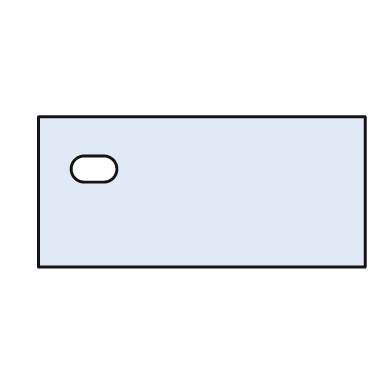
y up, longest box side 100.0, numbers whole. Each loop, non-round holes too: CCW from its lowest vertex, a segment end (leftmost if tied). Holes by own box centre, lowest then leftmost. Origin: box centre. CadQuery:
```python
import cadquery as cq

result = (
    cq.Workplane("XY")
    .moveTo(-50.0, -23.0)
    .lineTo(50.0, -23.0)
    .lineTo(50.0, 23.0)
    .lineTo(-50.0, 23.0)
    .close()
    .moveTo(-36.0, 3.0)
    .lineTo(-30.0, 3.0)
    .threePointArc((-26.0, 7.0), (-30.0, 11.0))
    .lineTo(-36.0, 11.0)
    .threePointArc((-40.0, 7.0), (-36.0, 3.0))
    .close()
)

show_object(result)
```